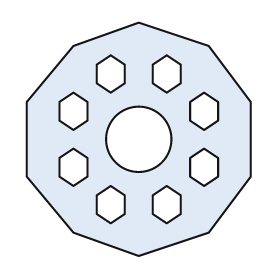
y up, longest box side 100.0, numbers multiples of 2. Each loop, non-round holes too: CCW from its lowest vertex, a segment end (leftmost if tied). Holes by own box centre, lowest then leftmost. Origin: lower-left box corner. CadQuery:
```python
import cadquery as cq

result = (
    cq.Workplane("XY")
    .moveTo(48.0, 0.0)
    .lineTo(78.0, 10.0)
    .lineTo(96.0, 34.0)
    .lineTo(96.0, 66.0)
    .lineTo(78.0, 90.0)
    .lineTo(48.0, 100.0)
    .lineTo(20.0, 90.0)
    .lineTo(0.0, 66.0)
    .lineTo(0.0, 34.0)
    .lineTo(20.0, 10.0)
    .close()
    .moveTo(36.0, 14.0)
    .lineTo(42.0, 18.0)
    .lineTo(42.0, 26.0)
    .lineTo(36.0, 30.0)
    .lineTo(30.0, 26.0)
    .lineTo(30.0, 18.0)
    .close()
    .moveTo(60.0, 14.0)
    .lineTo(66.0, 18.0)
    .lineTo(66.0, 26.0)
    .lineTo(60.0, 30.0)
    .lineTo(54.0, 26.0)
    .lineTo(54.0, 18.0)
    .close()
    .moveTo(20.0, 30.0)
    .lineTo(26.0, 34.0)
    .lineTo(26.0, 42.0)
    .lineTo(20.0, 46.0)
    .lineTo(14.0, 42.0)
    .lineTo(14.0, 34.0)
    .close()
    .moveTo(76.0, 30.0)
    .lineTo(82.0, 34.0)
    .lineTo(82.0, 42.0)
    .lineTo(76.0, 46.0)
    .lineTo(70.0, 42.0)
    .lineTo(70.0, 34.0)
    .close()
    .moveTo(48.0, 50.0)
    .circle(14.0)
    .moveTo(20.0, 54.0)
    .lineTo(26.0, 58.0)
    .lineTo(26.0, 66.0)
    .lineTo(20.0, 70.0)
    .lineTo(14.0, 66.0)
    .lineTo(14.0, 58.0)
    .close()
    .moveTo(76.0, 54.0)
    .lineTo(82.0, 58.0)
    .lineTo(82.0, 66.0)
    .lineTo(76.0, 70.0)
    .lineTo(70.0, 66.0)
    .lineTo(70.0, 58.0)
    .close()
    .moveTo(36.0, 70.0)
    .lineTo(42.0, 74.0)
    .lineTo(42.0, 82.0)
    .lineTo(36.0, 86.0)
    .lineTo(30.0, 82.0)
    .lineTo(30.0, 74.0)
    .close()
    .moveTo(60.0, 70.0)
    .lineTo(66.0, 74.0)
    .lineTo(66.0, 82.0)
    .lineTo(60.0, 86.0)
    .lineTo(54.0, 82.0)
    .lineTo(54.0, 74.0)
    .close()
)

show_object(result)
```